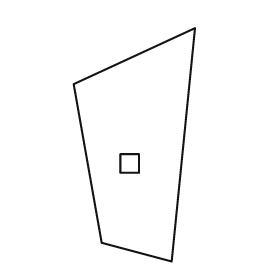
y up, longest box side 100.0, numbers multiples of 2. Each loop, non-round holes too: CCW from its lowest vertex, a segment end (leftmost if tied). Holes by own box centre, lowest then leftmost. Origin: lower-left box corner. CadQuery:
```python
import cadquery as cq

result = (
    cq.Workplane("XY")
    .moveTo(42.0, 0.0)
    .lineTo(52.0, 100.0)
    .lineTo(0.0, 76.0)
    .lineTo(12.0, 8.0)
    .close()
    .moveTo(20.0, 38.0)
    .lineTo(28.0, 38.0)
    .lineTo(28.0, 46.0)
    .lineTo(20.0, 46.0)
    .close()
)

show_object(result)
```